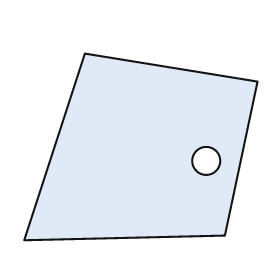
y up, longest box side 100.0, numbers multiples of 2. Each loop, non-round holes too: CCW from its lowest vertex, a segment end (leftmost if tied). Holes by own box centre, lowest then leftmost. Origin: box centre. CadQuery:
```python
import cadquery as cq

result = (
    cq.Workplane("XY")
    .moveTo(-50.0, -40.0)
    .lineTo(36.0, -38.0)
    .lineTo(50.0, 28.0)
    .lineTo(-24.0, 40.0)
    .close()
    .moveTo(28.0, -6.0)
    .circle(6.0)
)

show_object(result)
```